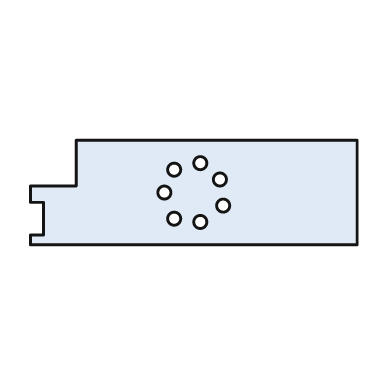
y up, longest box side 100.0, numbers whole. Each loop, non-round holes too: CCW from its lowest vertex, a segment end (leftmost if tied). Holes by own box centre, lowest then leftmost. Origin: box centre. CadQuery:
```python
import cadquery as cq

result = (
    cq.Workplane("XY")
    .moveTo(-50.0, -16.0)
    .lineTo(50.0, -16.0)
    .lineTo(50.0, 16.0)
    .lineTo(-36.0, 16.0)
    .lineTo(-36.0, 2.0)
    .lineTo(-50.0, 2.0)
    .lineTo(-50.0, -3.0)
    .lineTo(-46.0, -3.0)
    .lineTo(-46.0, -13.0)
    .lineTo(-50.0, -13.0)
    .close()
    .moveTo(2.0, -9.0)
    .circle(2.0)
    .moveTo(-6.0, -8.0)
    .circle(2.0)
    .moveTo(9.0, -4.0)
    .circle(2.0)
    .moveTo(-9.0, 0.0)
    .circle(2.0)
    .moveTo(8.0, 4.0)
    .circle(2.0)
    .moveTo(-6.0, 7.0)
    .circle(2.0)
    .moveTo(2.0, 9.0)
    .circle(2.0)
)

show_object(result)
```